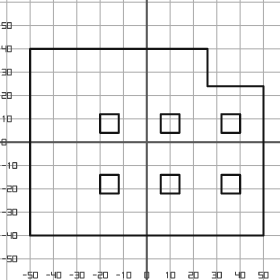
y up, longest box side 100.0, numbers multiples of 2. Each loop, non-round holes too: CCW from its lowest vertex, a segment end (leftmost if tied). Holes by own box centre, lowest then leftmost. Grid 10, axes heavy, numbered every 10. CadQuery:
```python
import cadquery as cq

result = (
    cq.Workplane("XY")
    .moveTo(-50.0, -40.0)
    .lineTo(50.0, -40.0)
    .lineTo(50.0, 24.0)
    .lineTo(26.0, 24.0)
    .lineTo(26.0, 40.0)
    .lineTo(-50.0, 40.0)
    .close()
    .moveTo(-20.0, -22.0)
    .lineTo(-12.0, -22.0)
    .lineTo(-12.0, -14.0)
    .lineTo(-20.0, -14.0)
    .close()
    .moveTo(6.0, -22.0)
    .lineTo(14.0, -22.0)
    .lineTo(14.0, -14.0)
    .lineTo(6.0, -14.0)
    .close()
    .moveTo(32.0, -22.0)
    .lineTo(40.0, -22.0)
    .lineTo(40.0, -14.0)
    .lineTo(32.0, -14.0)
    .close()
    .moveTo(-20.0, 4.0)
    .lineTo(-12.0, 4.0)
    .lineTo(-12.0, 12.0)
    .lineTo(-20.0, 12.0)
    .close()
    .moveTo(6.0, 4.0)
    .lineTo(14.0, 4.0)
    .lineTo(14.0, 12.0)
    .lineTo(6.0, 12.0)
    .close()
    .moveTo(32.0, 4.0)
    .lineTo(40.0, 4.0)
    .lineTo(40.0, 12.0)
    .lineTo(32.0, 12.0)
    .close()
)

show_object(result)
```